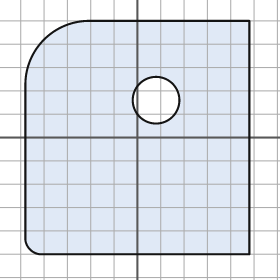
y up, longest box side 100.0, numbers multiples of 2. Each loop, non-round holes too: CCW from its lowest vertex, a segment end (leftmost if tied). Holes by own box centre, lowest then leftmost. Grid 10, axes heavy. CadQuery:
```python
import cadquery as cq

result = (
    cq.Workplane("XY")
    .moveTo(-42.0, -50.0)
    .lineTo(48.0, -50.0)
    .lineTo(48.0, 50.0)
    .lineTo(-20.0, 50.0)
    .threePointArc((-40.0, 42.0), (-48.0, 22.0))
    .lineTo(-48.0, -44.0)
    .threePointArc((-46.0, -48.0), (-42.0, -50.0))
    .close()
    .moveTo(8.0, 16.0)
    .circle(10.0)
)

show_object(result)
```